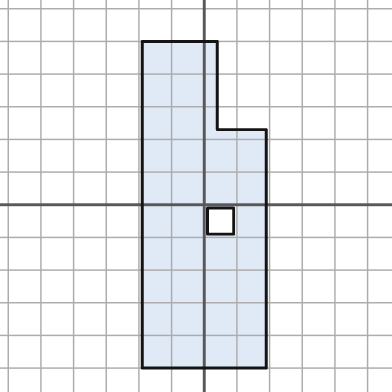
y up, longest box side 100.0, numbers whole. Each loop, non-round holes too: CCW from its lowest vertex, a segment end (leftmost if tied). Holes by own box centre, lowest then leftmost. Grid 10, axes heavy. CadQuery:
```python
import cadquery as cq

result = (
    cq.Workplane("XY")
    .moveTo(-19.0, -50.0)
    .lineTo(19.0, -50.0)
    .lineTo(19.0, 23.0)
    .lineTo(4.0, 23.0)
    .lineTo(4.0, 50.0)
    .lineTo(-19.0, 50.0)
    .close()
    .moveTo(1.0, -9.0)
    .lineTo(9.0, -9.0)
    .lineTo(9.0, -1.0)
    .lineTo(1.0, -1.0)
    .close()
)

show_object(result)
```